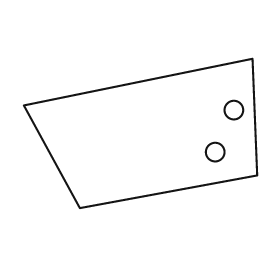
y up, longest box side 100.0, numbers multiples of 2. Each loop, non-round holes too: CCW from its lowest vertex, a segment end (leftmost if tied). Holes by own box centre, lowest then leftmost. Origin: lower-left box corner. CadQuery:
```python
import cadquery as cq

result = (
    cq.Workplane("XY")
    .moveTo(24.0, 0.0)
    .lineTo(100.0, 14.0)
    .lineTo(98.0, 64.0)
    .lineTo(0.0, 44.0)
    .close()
    .moveTo(82.0, 24.0)
    .circle(4.0)
    .moveTo(90.0, 42.0)
    .circle(4.0)
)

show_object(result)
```